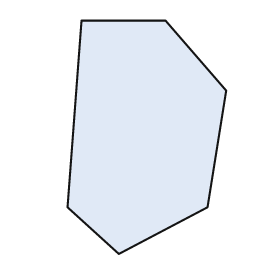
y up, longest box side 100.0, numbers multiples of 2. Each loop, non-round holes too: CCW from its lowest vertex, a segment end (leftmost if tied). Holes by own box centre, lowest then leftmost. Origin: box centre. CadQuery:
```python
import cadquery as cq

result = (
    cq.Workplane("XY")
    .moveTo(-12.0, -50.0)
    .lineTo(26.0, -30.0)
    .lineTo(34.0, 20.0)
    .lineTo(8.0, 50.0)
    .lineTo(-28.0, 50.0)
    .lineTo(-34.0, -30.0)
    .close()
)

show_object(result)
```